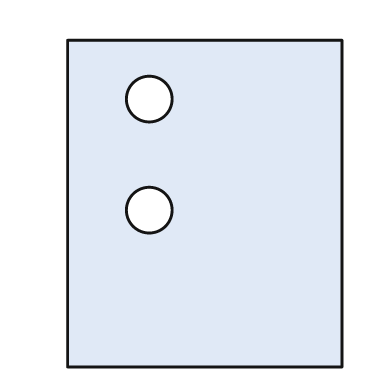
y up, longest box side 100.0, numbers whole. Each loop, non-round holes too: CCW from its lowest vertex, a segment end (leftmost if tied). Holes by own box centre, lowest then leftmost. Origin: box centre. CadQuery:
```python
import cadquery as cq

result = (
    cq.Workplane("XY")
    .moveTo(-42.0, -50.0)
    .lineTo(42.0, -50.0)
    .lineTo(42.0, 50.0)
    .lineTo(-42.0, 50.0)
    .close()
    .moveTo(-17.0, -2.0)
    .circle(7.0)
    .moveTo(-17.0, 32.0)
    .circle(7.0)
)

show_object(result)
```